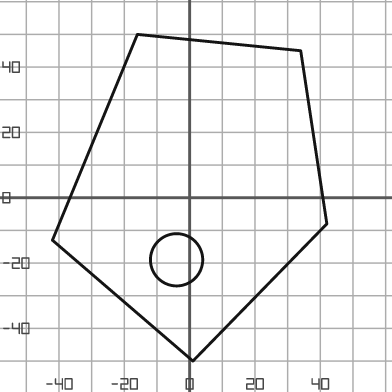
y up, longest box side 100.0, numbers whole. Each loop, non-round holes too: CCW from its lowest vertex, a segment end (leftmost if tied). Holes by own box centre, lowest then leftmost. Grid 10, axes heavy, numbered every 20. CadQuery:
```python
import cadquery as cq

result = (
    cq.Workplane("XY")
    .moveTo(1.0, -50.0)
    .lineTo(42.0, -8.0)
    .lineTo(34.0, 45.0)
    .lineTo(-16.0, 50.0)
    .lineTo(-42.0, -13.0)
    .close()
    .moveTo(-4.0, -19.0)
    .circle(8.0)
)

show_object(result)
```